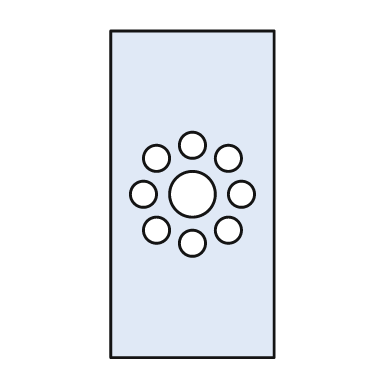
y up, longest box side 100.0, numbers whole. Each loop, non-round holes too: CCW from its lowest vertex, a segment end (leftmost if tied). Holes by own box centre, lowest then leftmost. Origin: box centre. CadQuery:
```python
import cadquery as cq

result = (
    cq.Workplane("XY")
    .moveTo(-25.0, -50.0)
    .lineTo(25.0, -50.0)
    .lineTo(25.0, 50.0)
    .lineTo(-25.0, 50.0)
    .close()
    .moveTo(0.0, -15.0)
    .circle(4.0)
    .moveTo(-11.0, -11.0)
    .circle(4.0)
    .moveTo(11.0, -11.0)
    .circle(4.0)
    .moveTo(-15.0, 0.0)
    .circle(4.0)
    .moveTo(0.0, 0.0)
    .circle(7.0)
    .moveTo(15.0, 0.0)
    .circle(4.0)
    .moveTo(-11.0, 11.0)
    .circle(4.0)
    .moveTo(11.0, 11.0)
    .circle(4.0)
    .moveTo(0.0, 15.0)
    .circle(4.0)
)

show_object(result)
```